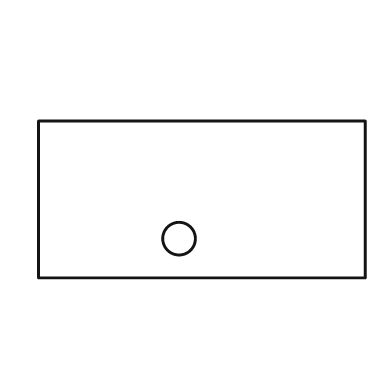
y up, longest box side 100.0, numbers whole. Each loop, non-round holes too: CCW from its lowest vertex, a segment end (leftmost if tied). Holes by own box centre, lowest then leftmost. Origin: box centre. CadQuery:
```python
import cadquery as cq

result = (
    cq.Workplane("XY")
    .moveTo(-50.0, -24.0)
    .lineTo(50.0, -24.0)
    .lineTo(50.0, 24.0)
    .lineTo(-50.0, 24.0)
    .close()
    .moveTo(-7.0, -12.0)
    .circle(5.0)
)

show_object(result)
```